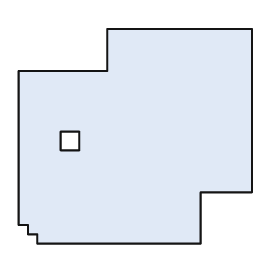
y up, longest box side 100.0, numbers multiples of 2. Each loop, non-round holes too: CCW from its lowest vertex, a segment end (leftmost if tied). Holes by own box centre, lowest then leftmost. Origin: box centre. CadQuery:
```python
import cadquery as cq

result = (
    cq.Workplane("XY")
    .moveTo(-42.0, -46.0)
    .lineTo(28.0, -46.0)
    .lineTo(28.0, -24.0)
    .lineTo(50.0, -24.0)
    .lineTo(50.0, 46.0)
    .lineTo(-12.0, 46.0)
    .lineTo(-12.0, 28.0)
    .lineTo(-50.0, 28.0)
    .lineTo(-50.0, -38.0)
    .lineTo(-46.0, -38.0)
    .lineTo(-46.0, -42.0)
    .lineTo(-42.0, -42.0)
    .close()
    .moveTo(-32.0, -6.0)
    .lineTo(-24.0, -6.0)
    .lineTo(-24.0, 2.0)
    .lineTo(-32.0, 2.0)
    .close()
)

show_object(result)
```